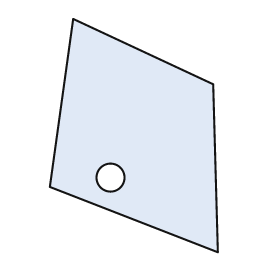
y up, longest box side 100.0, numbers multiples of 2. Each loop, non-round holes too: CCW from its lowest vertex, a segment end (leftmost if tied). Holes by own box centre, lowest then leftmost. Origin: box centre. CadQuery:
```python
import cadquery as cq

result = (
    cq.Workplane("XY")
    .moveTo(36.0, -50.0)
    .lineTo(34.0, 22.0)
    .lineTo(-26.0, 50.0)
    .lineTo(-36.0, -22.0)
    .close()
    .moveTo(-10.0, -18.0)
    .circle(6.0)
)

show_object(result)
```